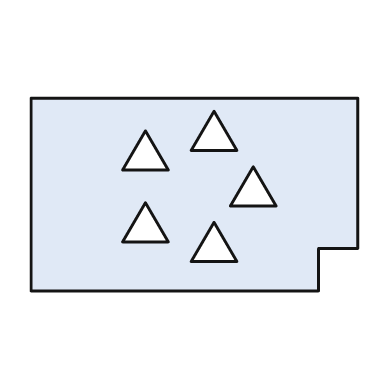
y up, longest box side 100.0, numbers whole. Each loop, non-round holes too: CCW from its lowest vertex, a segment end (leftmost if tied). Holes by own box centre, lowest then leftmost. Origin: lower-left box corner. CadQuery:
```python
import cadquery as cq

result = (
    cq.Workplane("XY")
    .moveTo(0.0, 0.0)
    .lineTo(88.0, 0.0)
    .lineTo(88.0, 13.0)
    .lineTo(100.0, 13.0)
    .lineTo(100.0, 59.0)
    .lineTo(0.0, 59.0)
    .close()
    .moveTo(49.0, 9.0)
    .lineTo(63.0, 9.0)
    .lineTo(56.0, 21.0)
    .close()
    .moveTo(28.0, 15.0)
    .lineTo(42.0, 15.0)
    .lineTo(35.0, 27.0)
    .close()
    .moveTo(61.0, 26.0)
    .lineTo(75.0, 26.0)
    .lineTo(68.0, 38.0)
    .close()
    .moveTo(28.0, 37.0)
    .lineTo(42.0, 37.0)
    .lineTo(35.0, 49.0)
    .close()
    .moveTo(49.0, 43.0)
    .lineTo(63.0, 43.0)
    .lineTo(56.0, 55.0)
    .close()
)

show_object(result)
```